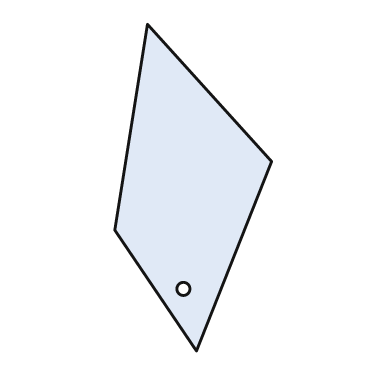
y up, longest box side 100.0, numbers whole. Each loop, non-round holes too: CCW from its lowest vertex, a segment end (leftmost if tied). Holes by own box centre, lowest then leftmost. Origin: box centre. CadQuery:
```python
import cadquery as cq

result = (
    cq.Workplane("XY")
    .moveTo(1.0, -50.0)
    .lineTo(24.0, 8.0)
    .lineTo(-14.0, 50.0)
    .lineTo(-24.0, -13.0)
    .close()
    .moveTo(-3.0, -31.0)
    .circle(2.0)
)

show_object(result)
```